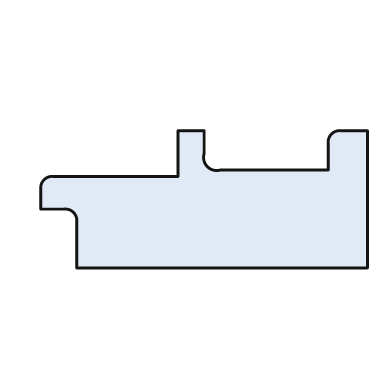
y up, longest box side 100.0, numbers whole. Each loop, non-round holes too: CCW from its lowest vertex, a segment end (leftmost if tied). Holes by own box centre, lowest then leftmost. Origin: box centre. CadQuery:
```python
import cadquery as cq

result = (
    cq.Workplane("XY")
    .moveTo(-39.0, -21.0)
    .lineTo(50.0, -21.0)
    .lineTo(50.0, 21.0)
    .lineTo(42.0, 21.0)
    .threePointArc((39.0, 20.0), (38.0, 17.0))
    .lineTo(38.0, 9.0)
    .lineTo(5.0, 9.0)
    .threePointArc((1.0, 10.0), (0.0, 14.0))
    .lineTo(0.0, 21.0)
    .lineTo(-8.0, 21.0)
    .lineTo(-8.0, 7.0)
    .lineTo(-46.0, 7.0)
    .threePointArc((-49.0, 6.0), (-50.0, 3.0))
    .lineTo(-50.0, -3.0)
    .lineTo(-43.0, -3.0)
    .threePointArc((-40.0, -4.0), (-39.0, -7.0))
    .close()
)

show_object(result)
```